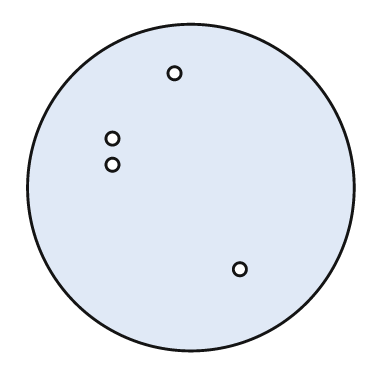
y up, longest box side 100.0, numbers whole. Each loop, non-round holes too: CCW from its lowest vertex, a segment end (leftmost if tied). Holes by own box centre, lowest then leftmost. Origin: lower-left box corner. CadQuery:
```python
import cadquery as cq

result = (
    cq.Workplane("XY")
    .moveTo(50.0, 50.0)
    .circle(50.0)
    .moveTo(65.0, 25.0)
    .circle(2.0)
    .moveTo(26.0, 57.0)
    .circle(2.0)
    .moveTo(26.0, 65.0)
    .circle(2.0)
    .moveTo(45.0, 85.0)
    .circle(2.0)
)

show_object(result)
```